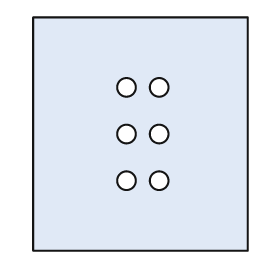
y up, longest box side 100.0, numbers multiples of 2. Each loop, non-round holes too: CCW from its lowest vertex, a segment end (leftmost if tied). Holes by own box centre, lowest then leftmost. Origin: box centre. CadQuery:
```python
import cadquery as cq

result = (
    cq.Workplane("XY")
    .moveTo(-46.0, -50.0)
    .lineTo(46.0, -50.0)
    .lineTo(46.0, 50.0)
    .lineTo(-46.0, 50.0)
    .close()
    .moveTo(-6.0, -20.0)
    .circle(4.0)
    .moveTo(8.0, -20.0)
    .circle(4.0)
    .moveTo(-6.0, 0.0)
    .circle(4.0)
    .moveTo(8.0, 0.0)
    .circle(4.0)
    .moveTo(-6.0, 20.0)
    .circle(4.0)
    .moveTo(8.0, 20.0)
    .circle(4.0)
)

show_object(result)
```